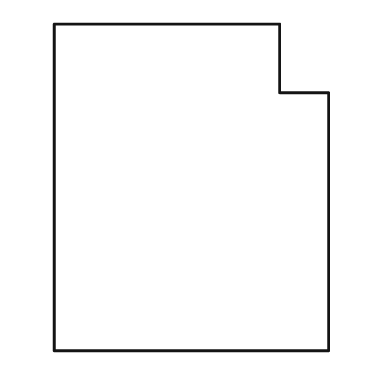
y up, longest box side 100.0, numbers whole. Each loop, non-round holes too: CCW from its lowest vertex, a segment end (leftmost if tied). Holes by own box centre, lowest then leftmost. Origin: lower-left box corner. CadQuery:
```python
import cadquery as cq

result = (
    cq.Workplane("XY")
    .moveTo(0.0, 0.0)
    .lineTo(84.0, 0.0)
    .lineTo(84.0, 79.0)
    .lineTo(69.0, 79.0)
    .lineTo(69.0, 100.0)
    .lineTo(0.0, 100.0)
    .close()
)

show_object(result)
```